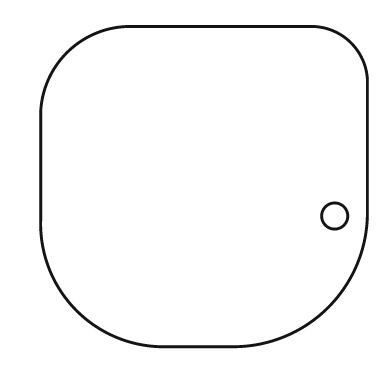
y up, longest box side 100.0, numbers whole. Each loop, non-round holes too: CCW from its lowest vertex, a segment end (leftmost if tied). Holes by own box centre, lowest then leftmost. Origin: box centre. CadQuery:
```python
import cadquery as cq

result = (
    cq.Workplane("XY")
    .moveTo(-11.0, -49.0)
    .lineTo(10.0, -49.0)
    .threePointArc((38.0, -37.0), (50.0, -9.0))
    .lineTo(50.0, 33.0)
    .threePointArc((45.0, 44.0), (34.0, 49.0))
    .lineTo(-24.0, 49.0)
    .threePointArc((-42.0, 41.0), (-50.0, 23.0))
    .lineTo(-50.0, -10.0)
    .threePointArc((-39.0, -38.0), (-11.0, -49.0))
    .close()
    .moveTo(40.0, -9.0)
    .circle(4.0)
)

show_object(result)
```